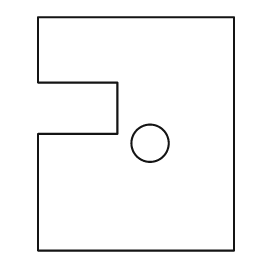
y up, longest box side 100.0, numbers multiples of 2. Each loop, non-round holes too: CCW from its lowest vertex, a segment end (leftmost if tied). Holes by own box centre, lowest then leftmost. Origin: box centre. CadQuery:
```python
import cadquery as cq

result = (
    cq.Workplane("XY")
    .moveTo(-42.0, -50.0)
    .lineTo(42.0, -50.0)
    .lineTo(42.0, 50.0)
    .lineTo(-42.0, 50.0)
    .lineTo(-42.0, 22.0)
    .lineTo(-8.0, 22.0)
    .lineTo(-8.0, 0.0)
    .lineTo(-42.0, 0.0)
    .close()
    .moveTo(6.0, -4.0)
    .circle(8.0)
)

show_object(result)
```